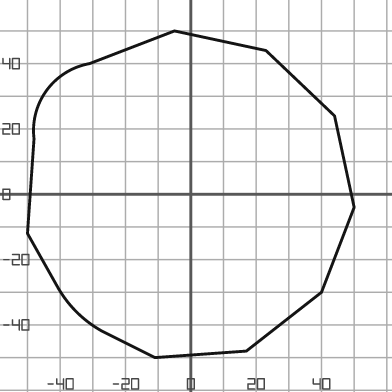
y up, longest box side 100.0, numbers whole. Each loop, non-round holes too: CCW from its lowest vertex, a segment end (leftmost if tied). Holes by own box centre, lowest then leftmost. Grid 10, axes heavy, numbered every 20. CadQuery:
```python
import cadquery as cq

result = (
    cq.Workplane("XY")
    .moveTo(-11.0, -50.0)
    .lineTo(17.0, -48.0)
    .lineTo(40.0, -30.0)
    .lineTo(50.0, -4.0)
    .lineTo(44.0, 24.0)
    .lineTo(23.0, 44.0)
    .lineTo(-5.0, 50.0)
    .lineTo(-31.0, 40.0)
    .threePointArc((-44.0, 32.0), (-48.0, 17.0))
    .lineTo(-50.0, -12.0)
    .lineTo(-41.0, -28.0)
    .threePointArc((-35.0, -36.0), (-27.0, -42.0))
    .close()
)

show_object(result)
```